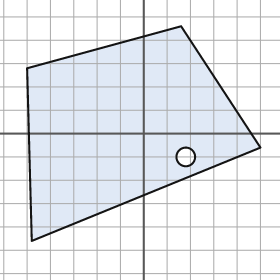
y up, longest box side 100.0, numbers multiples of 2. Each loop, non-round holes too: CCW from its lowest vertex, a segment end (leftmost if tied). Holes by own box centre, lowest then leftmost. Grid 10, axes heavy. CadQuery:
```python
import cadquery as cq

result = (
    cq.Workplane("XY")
    .moveTo(-48.0, -46.0)
    .lineTo(50.0, -6.0)
    .lineTo(16.0, 46.0)
    .lineTo(-50.0, 28.0)
    .close()
    .moveTo(18.0, -10.0)
    .circle(4.0)
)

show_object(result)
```